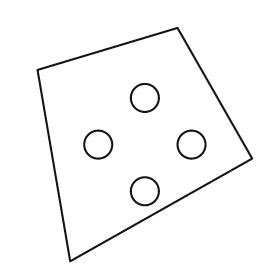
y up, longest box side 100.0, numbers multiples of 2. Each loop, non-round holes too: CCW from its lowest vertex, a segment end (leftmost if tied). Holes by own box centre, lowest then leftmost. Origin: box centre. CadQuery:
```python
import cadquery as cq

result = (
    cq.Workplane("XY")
    .moveTo(-32.0, -50.0)
    .lineTo(46.0, -6.0)
    .lineTo(14.0, 50.0)
    .lineTo(-46.0, 32.0)
    .close()
    .moveTo(0.0, -20.0)
    .circle(6.0)
    .moveTo(-20.0, 0.0)
    .circle(6.0)
    .moveTo(20.0, 0.0)
    .circle(6.0)
    .moveTo(0.0, 20.0)
    .circle(6.0)
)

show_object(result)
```